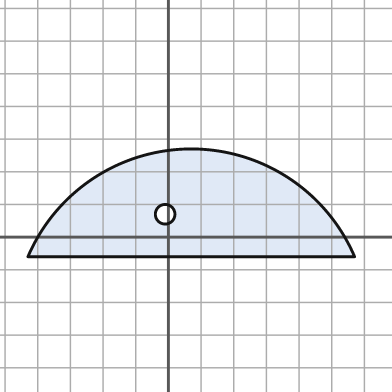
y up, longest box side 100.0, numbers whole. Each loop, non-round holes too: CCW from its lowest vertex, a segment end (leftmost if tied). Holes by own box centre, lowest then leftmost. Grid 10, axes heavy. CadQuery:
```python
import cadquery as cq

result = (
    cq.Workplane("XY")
    .moveTo(-43.0, -6.0)
    .lineTo(57.0, -6.0)
    .threePointArc((7.0, 27.0), (-43.0, -6.0))
    .close()
    .moveTo(-1.0, 7.0)
    .circle(3.0)
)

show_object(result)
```